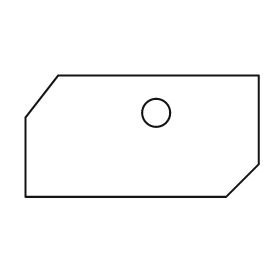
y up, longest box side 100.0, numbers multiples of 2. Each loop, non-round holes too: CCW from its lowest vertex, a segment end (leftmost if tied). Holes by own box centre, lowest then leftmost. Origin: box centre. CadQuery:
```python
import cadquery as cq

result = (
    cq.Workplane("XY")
    .moveTo(-50.0, -26.0)
    .lineTo(36.0, -26.0)
    .lineTo(50.0, -12.0)
    .lineTo(50.0, 26.0)
    .lineTo(-36.0, 26.0)
    .lineTo(-50.0, 8.0)
    .close()
    .moveTo(6.0, 10.0)
    .circle(6.0)
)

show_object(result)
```